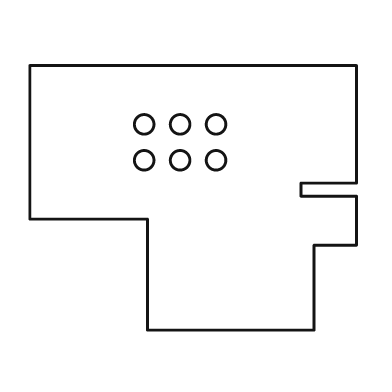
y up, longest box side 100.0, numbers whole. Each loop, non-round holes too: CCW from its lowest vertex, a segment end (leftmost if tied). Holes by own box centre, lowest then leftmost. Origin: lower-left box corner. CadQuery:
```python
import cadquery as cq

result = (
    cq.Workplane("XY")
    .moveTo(36.0, 0.0)
    .lineTo(87.0, 0.0)
    .lineTo(87.0, 26.0)
    .lineTo(100.0, 26.0)
    .lineTo(100.0, 41.0)
    .lineTo(83.0, 41.0)
    .lineTo(83.0, 45.0)
    .lineTo(100.0, 45.0)
    .lineTo(100.0, 81.0)
    .lineTo(0.0, 81.0)
    .lineTo(0.0, 34.0)
    .lineTo(36.0, 34.0)
    .close()
    .moveTo(35.0, 52.0)
    .circle(3.0)
    .moveTo(46.0, 52.0)
    .circle(3.0)
    .moveTo(57.0, 52.0)
    .circle(3.0)
    .moveTo(35.0, 63.0)
    .circle(3.0)
    .moveTo(46.0, 63.0)
    .circle(3.0)
    .moveTo(57.0, 63.0)
    .circle(3.0)
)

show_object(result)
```